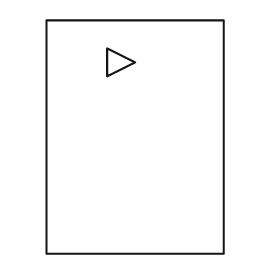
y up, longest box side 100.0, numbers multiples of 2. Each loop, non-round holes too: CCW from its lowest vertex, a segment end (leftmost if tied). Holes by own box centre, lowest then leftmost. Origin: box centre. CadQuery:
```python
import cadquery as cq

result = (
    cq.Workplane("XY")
    .moveTo(-38.0, -50.0)
    .lineTo(38.0, -50.0)
    .lineTo(38.0, 50.0)
    .lineTo(-38.0, 50.0)
    .close()
    .moveTo(-12.0, 26.0)
    .lineTo(0.0, 32.0)
    .lineTo(-12.0, 38.0)
    .close()
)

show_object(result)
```